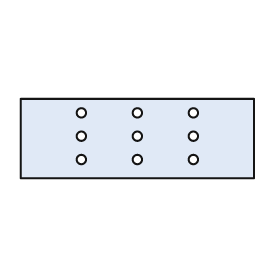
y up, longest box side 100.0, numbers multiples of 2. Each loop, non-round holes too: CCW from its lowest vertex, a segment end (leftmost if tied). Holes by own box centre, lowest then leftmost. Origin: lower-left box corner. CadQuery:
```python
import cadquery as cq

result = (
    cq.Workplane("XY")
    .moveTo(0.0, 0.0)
    .lineTo(100.0, 0.0)
    .lineTo(100.0, 34.0)
    .lineTo(0.0, 34.0)
    .close()
    .moveTo(26.0, 8.0)
    .circle(2.0)
    .moveTo(50.0, 8.0)
    .circle(2.0)
    .moveTo(74.0, 8.0)
    .circle(2.0)
    .moveTo(26.0, 18.0)
    .circle(2.0)
    .moveTo(50.0, 18.0)
    .circle(2.0)
    .moveTo(74.0, 18.0)
    .circle(2.0)
    .moveTo(26.0, 28.0)
    .circle(2.0)
    .moveTo(50.0, 28.0)
    .circle(2.0)
    .moveTo(74.0, 28.0)
    .circle(2.0)
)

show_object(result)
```